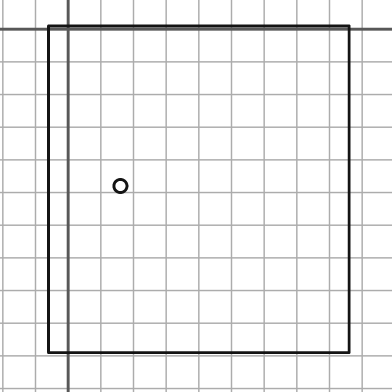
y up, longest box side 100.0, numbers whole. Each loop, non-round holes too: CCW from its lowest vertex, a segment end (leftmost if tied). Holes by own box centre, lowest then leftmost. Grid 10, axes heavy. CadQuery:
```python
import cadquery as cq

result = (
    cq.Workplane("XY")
    .moveTo(-6.0, -99.0)
    .lineTo(86.0, -99.0)
    .lineTo(86.0, 1.0)
    .lineTo(-6.0, 1.0)
    .close()
    .moveTo(16.0, -48.0)
    .circle(2.0)
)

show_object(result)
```